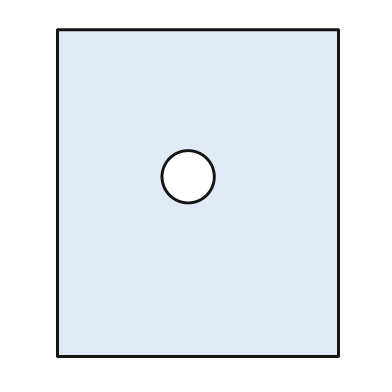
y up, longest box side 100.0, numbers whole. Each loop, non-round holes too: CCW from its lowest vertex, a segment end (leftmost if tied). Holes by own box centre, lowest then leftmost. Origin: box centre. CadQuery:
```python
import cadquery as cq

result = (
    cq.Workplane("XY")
    .moveTo(-43.0, -50.0)
    .lineTo(43.0, -50.0)
    .lineTo(43.0, 50.0)
    .lineTo(-43.0, 50.0)
    .close()
    .moveTo(-3.0, 5.0)
    .circle(8.0)
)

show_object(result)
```